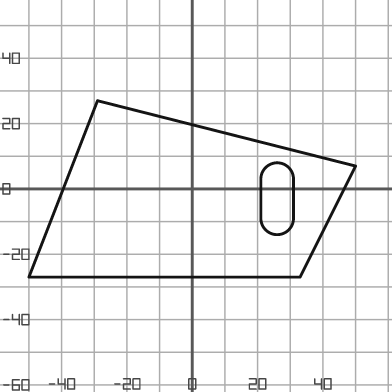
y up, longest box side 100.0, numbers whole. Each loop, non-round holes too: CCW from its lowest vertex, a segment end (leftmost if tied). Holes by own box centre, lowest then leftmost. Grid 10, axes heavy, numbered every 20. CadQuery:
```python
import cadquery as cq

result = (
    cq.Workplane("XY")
    .moveTo(-50.0, -27.0)
    .lineTo(33.0, -27.0)
    .lineTo(50.0, 7.0)
    .lineTo(-29.0, 27.0)
    .close()
    .moveTo(21.0, -9.0)
    .threePointArc((26.0, -14.0), (31.0, -9.0))
    .lineTo(31.0, 3.0)
    .threePointArc((26.0, 8.0), (21.0, 3.0))
    .close()
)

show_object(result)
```